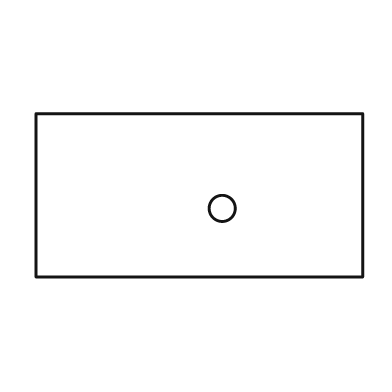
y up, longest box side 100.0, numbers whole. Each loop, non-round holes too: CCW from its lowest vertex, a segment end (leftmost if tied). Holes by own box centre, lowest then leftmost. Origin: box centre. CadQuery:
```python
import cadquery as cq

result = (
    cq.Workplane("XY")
    .moveTo(-50.0, -25.0)
    .lineTo(50.0, -25.0)
    .lineTo(50.0, 25.0)
    .lineTo(-50.0, 25.0)
    .close()
    .moveTo(7.0, -4.0)
    .circle(4.0)
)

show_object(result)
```